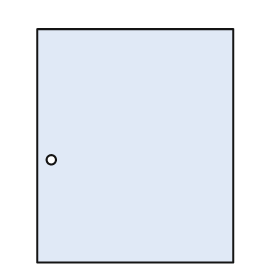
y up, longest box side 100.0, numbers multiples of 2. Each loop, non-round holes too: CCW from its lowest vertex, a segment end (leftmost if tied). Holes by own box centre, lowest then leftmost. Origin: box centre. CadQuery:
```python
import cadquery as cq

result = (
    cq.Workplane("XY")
    .moveTo(-42.0, -50.0)
    .lineTo(42.0, -50.0)
    .lineTo(42.0, 50.0)
    .lineTo(-42.0, 50.0)
    .close()
    .moveTo(-36.0, -6.0)
    .circle(2.0)
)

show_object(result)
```